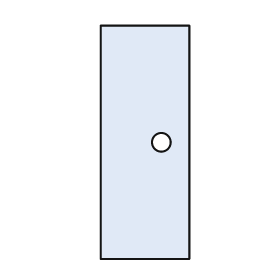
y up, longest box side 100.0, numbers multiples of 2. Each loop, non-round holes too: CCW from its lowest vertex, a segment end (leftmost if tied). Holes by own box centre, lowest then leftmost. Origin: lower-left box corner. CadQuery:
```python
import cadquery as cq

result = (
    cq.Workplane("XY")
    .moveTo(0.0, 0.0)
    .lineTo(38.0, 0.0)
    .lineTo(38.0, 100.0)
    .lineTo(0.0, 100.0)
    .close()
    .moveTo(26.0, 50.0)
    .circle(4.0)
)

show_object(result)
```